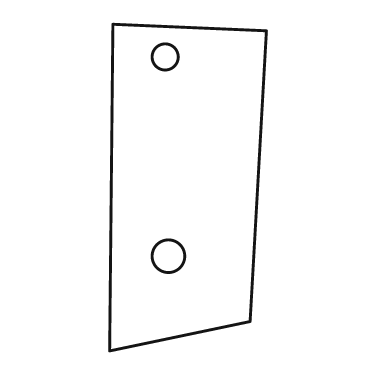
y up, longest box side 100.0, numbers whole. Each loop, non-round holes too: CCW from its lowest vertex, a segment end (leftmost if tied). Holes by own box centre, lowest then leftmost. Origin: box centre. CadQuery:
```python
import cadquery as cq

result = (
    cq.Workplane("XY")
    .moveTo(-24.0, -50.0)
    .lineTo(19.0, -41.0)
    .lineTo(24.0, 48.0)
    .lineTo(-23.0, 50.0)
    .close()
    .moveTo(-6.0, -21.0)
    .circle(5.0)
    .moveTo(-7.0, 40.0)
    .circle(4.0)
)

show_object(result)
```